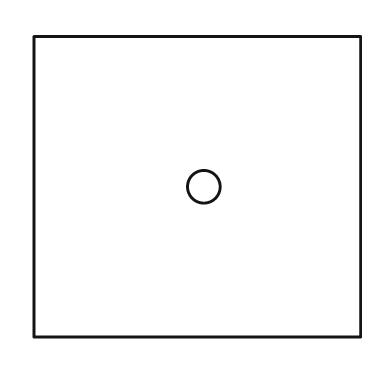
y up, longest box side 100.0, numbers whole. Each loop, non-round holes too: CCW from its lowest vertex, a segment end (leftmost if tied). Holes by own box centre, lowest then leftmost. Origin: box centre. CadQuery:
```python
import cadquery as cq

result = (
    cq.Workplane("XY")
    .moveTo(-50.0, -46.0)
    .lineTo(50.0, -46.0)
    .lineTo(50.0, 46.0)
    .lineTo(-50.0, 46.0)
    .close()
    .moveTo(2.0, 0.0)
    .circle(5.0)
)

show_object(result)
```